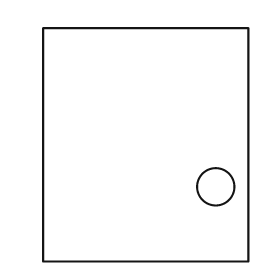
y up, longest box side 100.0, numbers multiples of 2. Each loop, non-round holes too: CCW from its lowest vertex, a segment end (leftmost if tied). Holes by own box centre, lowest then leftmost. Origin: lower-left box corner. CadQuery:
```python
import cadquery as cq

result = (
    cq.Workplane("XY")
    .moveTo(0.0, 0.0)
    .lineTo(88.0, 0.0)
    .lineTo(88.0, 100.0)
    .lineTo(0.0, 100.0)
    .close()
    .moveTo(74.0, 32.0)
    .circle(8.0)
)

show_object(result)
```